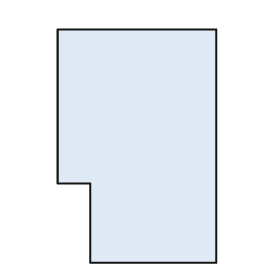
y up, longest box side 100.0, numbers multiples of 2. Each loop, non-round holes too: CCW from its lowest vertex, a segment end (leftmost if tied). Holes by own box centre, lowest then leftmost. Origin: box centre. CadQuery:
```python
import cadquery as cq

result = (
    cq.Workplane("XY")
    .moveTo(-20.0, -50.0)
    .lineTo(34.0, -50.0)
    .lineTo(34.0, 50.0)
    .lineTo(-34.0, 50.0)
    .lineTo(-34.0, -16.0)
    .lineTo(-20.0, -16.0)
    .close()
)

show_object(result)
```